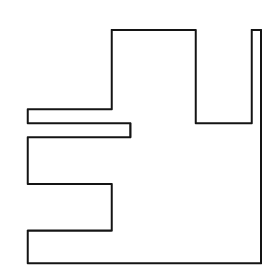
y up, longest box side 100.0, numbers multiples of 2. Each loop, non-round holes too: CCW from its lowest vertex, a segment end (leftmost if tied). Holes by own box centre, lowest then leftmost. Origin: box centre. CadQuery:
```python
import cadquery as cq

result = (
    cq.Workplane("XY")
    .moveTo(-50.0, -50.0)
    .lineTo(50.0, -50.0)
    .lineTo(50.0, 50.0)
    .lineTo(46.0, 50.0)
    .lineTo(46.0, 10.0)
    .lineTo(22.0, 10.0)
    .lineTo(22.0, 50.0)
    .lineTo(-14.0, 50.0)
    .lineTo(-14.0, 16.0)
    .lineTo(-50.0, 16.0)
    .lineTo(-50.0, 10.0)
    .lineTo(-6.0, 10.0)
    .lineTo(-6.0, 4.0)
    .lineTo(-50.0, 4.0)
    .lineTo(-50.0, -16.0)
    .lineTo(-14.0, -16.0)
    .lineTo(-14.0, -36.0)
    .lineTo(-50.0, -36.0)
    .close()
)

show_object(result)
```